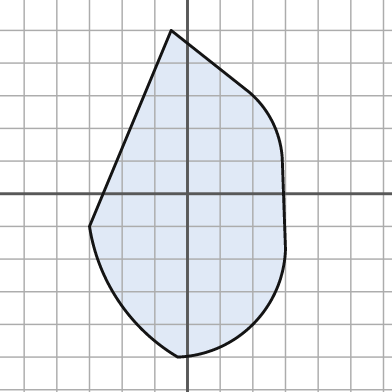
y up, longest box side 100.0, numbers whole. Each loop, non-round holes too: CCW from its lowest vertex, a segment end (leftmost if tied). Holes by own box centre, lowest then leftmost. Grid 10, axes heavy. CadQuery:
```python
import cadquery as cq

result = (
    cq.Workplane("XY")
    .moveTo(-3.0, -50.0)
    .threePointArc((20.0, -40.0), (30.0, -17.0))
    .lineTo(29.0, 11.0)
    .threePointArc((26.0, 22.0), (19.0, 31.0))
    .lineTo(-5.0, 50.0)
    .lineTo(-30.0, -10.0)
    .threePointArc((-21.0, -33.0), (-3.0, -50.0))
    .close()
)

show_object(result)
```